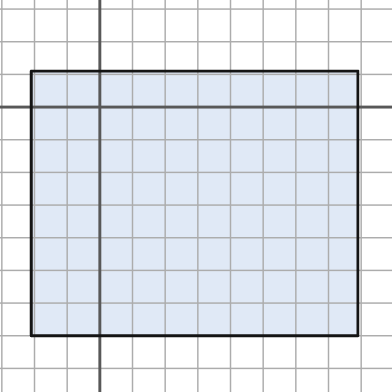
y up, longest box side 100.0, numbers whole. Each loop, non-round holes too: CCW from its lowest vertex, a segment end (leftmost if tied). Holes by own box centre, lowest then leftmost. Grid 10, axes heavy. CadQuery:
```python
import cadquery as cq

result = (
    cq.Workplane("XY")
    .moveTo(-21.0, -70.0)
    .lineTo(79.0, -70.0)
    .lineTo(79.0, 11.0)
    .lineTo(-21.0, 11.0)
    .close()
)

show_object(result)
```